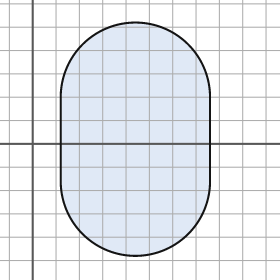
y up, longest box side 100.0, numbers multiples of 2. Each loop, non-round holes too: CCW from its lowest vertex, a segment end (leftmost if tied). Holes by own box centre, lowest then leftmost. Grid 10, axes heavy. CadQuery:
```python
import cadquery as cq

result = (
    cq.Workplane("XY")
    .moveTo(12.0, -16.0)
    .threePointArc((44.0, -48.0), (76.0, -16.0))
    .lineTo(76.0, 20.0)
    .threePointArc((44.0, 52.0), (12.0, 20.0))
    .close()
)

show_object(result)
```